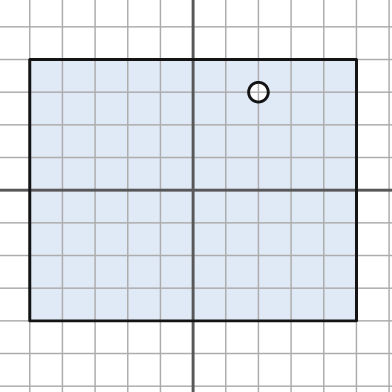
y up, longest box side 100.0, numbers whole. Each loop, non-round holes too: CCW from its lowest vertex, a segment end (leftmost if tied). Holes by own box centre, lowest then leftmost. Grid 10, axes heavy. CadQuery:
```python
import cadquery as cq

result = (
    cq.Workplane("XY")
    .moveTo(-50.0, -40.0)
    .lineTo(50.0, -40.0)
    .lineTo(50.0, 40.0)
    .lineTo(-50.0, 40.0)
    .close()
    .moveTo(20.0, 30.0)
    .circle(3.0)
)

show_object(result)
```